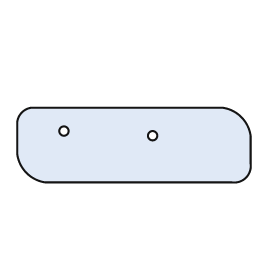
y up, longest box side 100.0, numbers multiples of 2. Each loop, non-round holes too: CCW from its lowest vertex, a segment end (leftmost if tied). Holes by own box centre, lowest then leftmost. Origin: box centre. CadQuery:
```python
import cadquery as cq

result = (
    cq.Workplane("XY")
    .moveTo(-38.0, -16.0)
    .lineTo(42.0, -16.0)
    .threePointArc((48.0, -14.0), (50.0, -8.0))
    .lineTo(50.0, 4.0)
    .threePointArc((46.0, 12.0), (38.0, 16.0))
    .lineTo(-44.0, 16.0)
    .threePointArc((-48.0, 14.0), (-50.0, 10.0))
    .lineTo(-50.0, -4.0)
    .threePointArc((-46.0, -12.0), (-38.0, -16.0))
    .close()
    .moveTo(8.0, 4.0)
    .circle(2.0)
    .moveTo(-30.0, 6.0)
    .circle(2.0)
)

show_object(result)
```